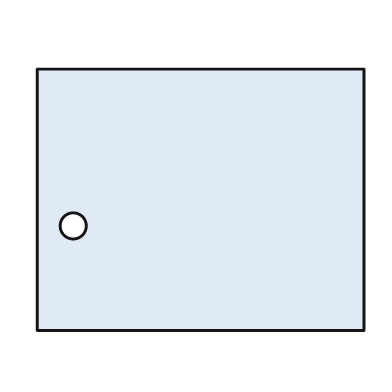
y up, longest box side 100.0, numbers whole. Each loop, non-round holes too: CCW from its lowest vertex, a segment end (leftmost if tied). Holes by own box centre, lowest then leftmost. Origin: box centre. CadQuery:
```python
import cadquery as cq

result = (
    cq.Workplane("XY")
    .moveTo(-50.0, -40.0)
    .lineTo(50.0, -40.0)
    .lineTo(50.0, 40.0)
    .lineTo(-50.0, 40.0)
    .close()
    .moveTo(-39.0, -8.0)
    .circle(4.0)
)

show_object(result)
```